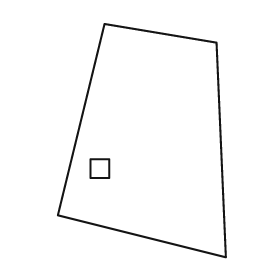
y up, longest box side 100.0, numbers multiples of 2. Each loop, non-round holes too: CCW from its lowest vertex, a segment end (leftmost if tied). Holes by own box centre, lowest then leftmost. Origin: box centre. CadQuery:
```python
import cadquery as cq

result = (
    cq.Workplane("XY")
    .moveTo(36.0, -50.0)
    .lineTo(32.0, 42.0)
    .lineTo(-16.0, 50.0)
    .lineTo(-36.0, -32.0)
    .close()
    .moveTo(-22.0, -16.0)
    .lineTo(-14.0, -16.0)
    .lineTo(-14.0, -8.0)
    .lineTo(-22.0, -8.0)
    .close()
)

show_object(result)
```